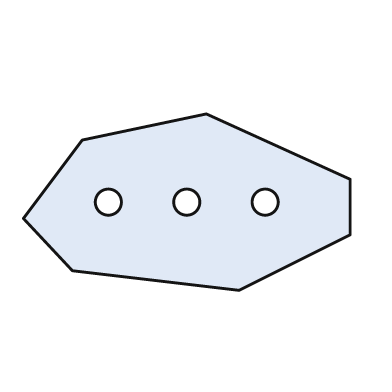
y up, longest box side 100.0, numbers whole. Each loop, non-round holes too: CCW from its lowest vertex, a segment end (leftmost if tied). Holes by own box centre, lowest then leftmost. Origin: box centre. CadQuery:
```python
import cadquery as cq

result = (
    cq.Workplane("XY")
    .moveTo(16.0, -27.0)
    .lineTo(50.0, -10.0)
    .lineTo(50.0, 7.0)
    .lineTo(6.0, 27.0)
    .lineTo(-32.0, 19.0)
    .lineTo(-50.0, -5.0)
    .lineTo(-35.0, -21.0)
    .close()
    .moveTo(-24.0, 0.0)
    .circle(4.0)
    .moveTo(0.0, 0.0)
    .circle(4.0)
    .moveTo(24.0, 0.0)
    .circle(4.0)
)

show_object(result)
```